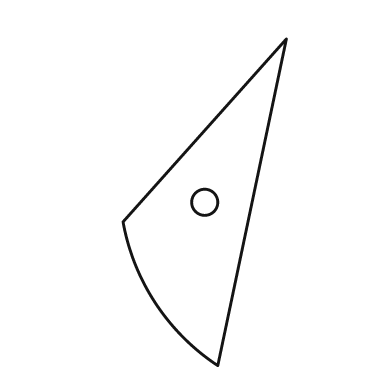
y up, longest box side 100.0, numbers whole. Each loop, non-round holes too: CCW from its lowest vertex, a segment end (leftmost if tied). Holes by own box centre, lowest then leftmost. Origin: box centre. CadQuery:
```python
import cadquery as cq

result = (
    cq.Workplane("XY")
    .moveTo(4.0, -50.0)
    .lineTo(25.0, 50.0)
    .lineTo(-25.0, -6.0)
    .threePointArc((-15.0, -31.0), (4.0, -50.0))
    .close()
    .moveTo(0.0, 0.0)
    .circle(4.0)
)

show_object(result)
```